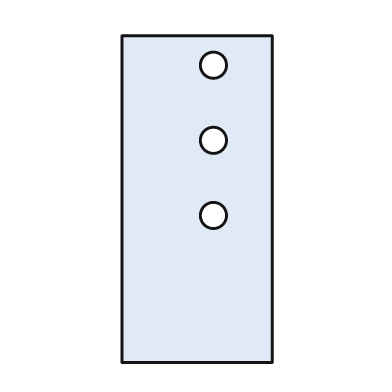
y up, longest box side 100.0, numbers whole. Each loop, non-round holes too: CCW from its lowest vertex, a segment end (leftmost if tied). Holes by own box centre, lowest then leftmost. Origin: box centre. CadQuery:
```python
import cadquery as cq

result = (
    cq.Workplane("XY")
    .moveTo(-23.0, -50.0)
    .lineTo(23.0, -50.0)
    .lineTo(23.0, 50.0)
    .lineTo(-23.0, 50.0)
    .close()
    .moveTo(5.0, -5.0)
    .circle(4.0)
    .moveTo(5.0, 18.0)
    .circle(4.0)
    .moveTo(5.0, 41.0)
    .circle(4.0)
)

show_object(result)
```